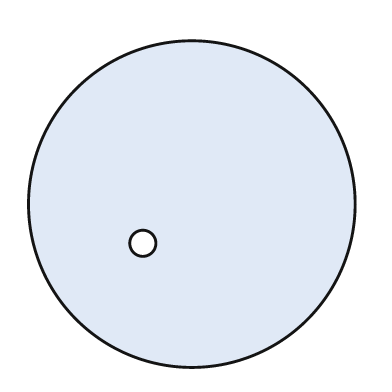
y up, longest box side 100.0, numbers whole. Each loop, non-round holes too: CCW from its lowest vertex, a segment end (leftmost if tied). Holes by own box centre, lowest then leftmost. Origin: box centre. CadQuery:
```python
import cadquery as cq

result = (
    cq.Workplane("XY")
    .moveTo(0.0, 0.0)
    .circle(50.0)
    .moveTo(-15.0, -12.0)
    .circle(4.0)
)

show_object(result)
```